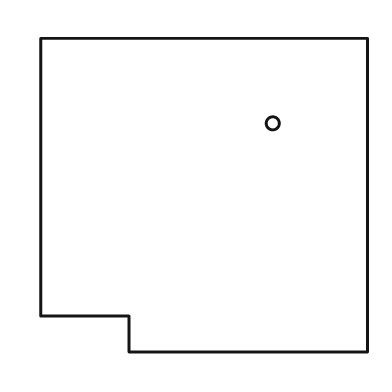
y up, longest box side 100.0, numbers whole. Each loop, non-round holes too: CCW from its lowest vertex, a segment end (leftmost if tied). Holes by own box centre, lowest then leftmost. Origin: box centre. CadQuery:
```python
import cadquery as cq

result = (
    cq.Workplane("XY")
    .moveTo(-23.0, -48.0)
    .lineTo(50.0, -48.0)
    .lineTo(50.0, 48.0)
    .lineTo(-50.0, 48.0)
    .lineTo(-50.0, -37.0)
    .lineTo(-23.0, -37.0)
    .close()
    .moveTo(21.0, 22.0)
    .circle(2.0)
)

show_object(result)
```